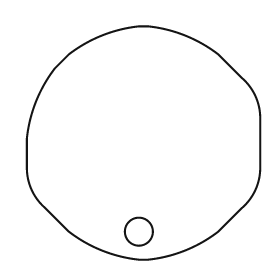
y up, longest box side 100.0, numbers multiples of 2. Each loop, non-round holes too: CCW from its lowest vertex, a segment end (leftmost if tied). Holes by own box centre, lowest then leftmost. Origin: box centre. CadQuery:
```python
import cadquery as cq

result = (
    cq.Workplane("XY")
    .moveTo(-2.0, -50.0)
    .lineTo(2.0, -50.0)
    .threePointArc((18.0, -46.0), (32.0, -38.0))
    .lineTo(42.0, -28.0)
    .threePointArc((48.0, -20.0), (50.0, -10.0))
    .lineTo(50.0, 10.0)
    .threePointArc((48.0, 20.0), (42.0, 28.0))
    .lineTo(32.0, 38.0)
    .threePointArc((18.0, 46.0), (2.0, 50.0))
    .lineTo(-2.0, 50.0)
    .threePointArc((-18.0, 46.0), (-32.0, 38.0))
    .lineTo(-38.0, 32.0)
    .threePointArc((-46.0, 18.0), (-50.0, 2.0))
    .lineTo(-50.0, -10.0)
    .threePointArc((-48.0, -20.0), (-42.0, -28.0))
    .lineTo(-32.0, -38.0)
    .threePointArc((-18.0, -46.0), (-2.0, -50.0))
    .close()
    .moveTo(-2.0, -38.0)
    .circle(6.0)
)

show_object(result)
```